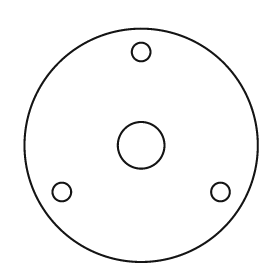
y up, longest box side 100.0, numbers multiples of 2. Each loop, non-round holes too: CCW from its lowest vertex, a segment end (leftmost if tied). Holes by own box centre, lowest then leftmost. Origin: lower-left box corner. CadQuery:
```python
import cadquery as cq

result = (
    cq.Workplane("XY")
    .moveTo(50.0, 50.0)
    .circle(50.0)
    .moveTo(16.0, 30.0)
    .circle(4.0)
    .moveTo(84.0, 30.0)
    .circle(4.0)
    .moveTo(50.0, 50.0)
    .circle(10.0)
    .moveTo(50.0, 90.0)
    .circle(4.0)
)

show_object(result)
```